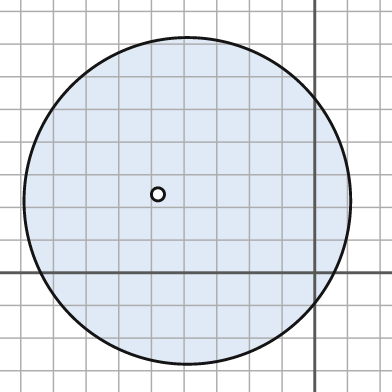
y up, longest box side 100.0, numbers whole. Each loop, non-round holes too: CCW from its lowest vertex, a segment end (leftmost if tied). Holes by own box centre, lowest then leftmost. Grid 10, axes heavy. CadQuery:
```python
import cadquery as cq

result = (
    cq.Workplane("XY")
    .moveTo(-39.0, 22.0)
    .circle(50.0)
    .moveTo(-48.0, 24.0)
    .circle(2.0)
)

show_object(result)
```